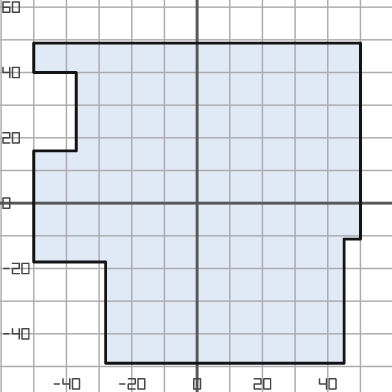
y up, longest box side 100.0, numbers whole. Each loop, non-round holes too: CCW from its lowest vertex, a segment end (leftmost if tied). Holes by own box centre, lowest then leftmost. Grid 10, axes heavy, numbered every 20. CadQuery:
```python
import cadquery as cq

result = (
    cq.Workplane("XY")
    .moveTo(-28.0, -49.0)
    .lineTo(45.0, -49.0)
    .lineTo(45.0, -11.0)
    .lineTo(50.0, -11.0)
    .lineTo(50.0, 49.0)
    .lineTo(-50.0, 49.0)
    .lineTo(-50.0, 40.0)
    .lineTo(-37.0, 40.0)
    .lineTo(-37.0, 16.0)
    .lineTo(-50.0, 16.0)
    .lineTo(-50.0, -18.0)
    .lineTo(-28.0, -18.0)
    .close()
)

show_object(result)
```